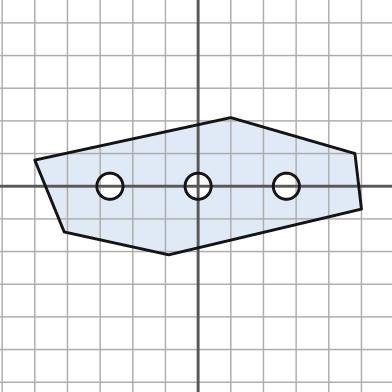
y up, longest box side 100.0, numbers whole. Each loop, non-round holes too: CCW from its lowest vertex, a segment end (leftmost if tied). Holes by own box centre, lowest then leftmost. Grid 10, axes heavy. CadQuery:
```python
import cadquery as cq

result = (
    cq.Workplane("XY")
    .moveTo(-9.0, -21.0)
    .lineTo(50.0, -7.0)
    .lineTo(48.0, 10.0)
    .lineTo(10.0, 21.0)
    .lineTo(-50.0, 8.0)
    .lineTo(-41.0, -14.0)
    .close()
    .moveTo(-27.0, 0.0)
    .circle(4.0)
    .moveTo(0.0, 0.0)
    .circle(4.0)
    .moveTo(27.0, 0.0)
    .circle(4.0)
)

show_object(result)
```